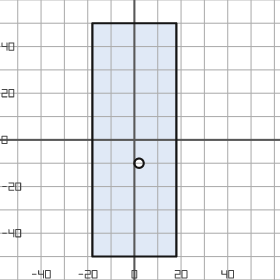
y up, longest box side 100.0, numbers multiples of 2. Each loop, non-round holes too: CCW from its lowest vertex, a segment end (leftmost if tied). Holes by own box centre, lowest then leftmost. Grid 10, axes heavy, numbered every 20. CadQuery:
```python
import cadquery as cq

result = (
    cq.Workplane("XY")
    .moveTo(-18.0, -50.0)
    .lineTo(18.0, -50.0)
    .lineTo(18.0, 50.0)
    .lineTo(-18.0, 50.0)
    .close()
    .moveTo(2.0, -10.0)
    .circle(2.0)
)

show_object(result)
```